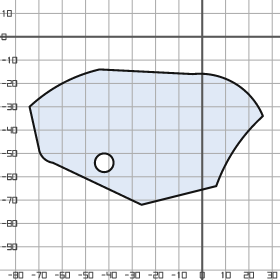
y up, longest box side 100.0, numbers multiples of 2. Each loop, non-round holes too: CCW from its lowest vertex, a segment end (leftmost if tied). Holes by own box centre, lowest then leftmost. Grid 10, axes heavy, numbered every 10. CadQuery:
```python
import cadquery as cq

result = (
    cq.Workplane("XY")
    .moveTo(-26.0, -72.0)
    .lineTo(6.0, -64.0)
    .threePointArc((14.0, -48.0), (26.0, -34.0))
    .threePointArc((14.0, -20.0), (-4.0, -16.0))
    .lineTo(-44.0, -14.0)
    .threePointArc((-60.0, -20.0), (-74.0, -30.0))
    .lineTo(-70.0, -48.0)
    .threePointArc((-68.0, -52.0), (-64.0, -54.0))
    .close()
    .moveTo(-42.0, -54.0)
    .circle(4.0)
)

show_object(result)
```